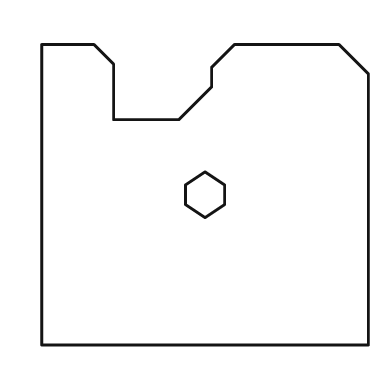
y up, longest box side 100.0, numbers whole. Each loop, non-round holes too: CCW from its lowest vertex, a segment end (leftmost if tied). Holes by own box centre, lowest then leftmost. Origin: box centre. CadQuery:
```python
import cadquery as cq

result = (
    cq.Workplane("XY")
    .moveTo(-50.0, -46.0)
    .lineTo(50.0, -46.0)
    .lineTo(50.0, 37.0)
    .lineTo(41.0, 46.0)
    .lineTo(9.0, 46.0)
    .lineTo(2.0, 39.0)
    .lineTo(2.0, 33.0)
    .lineTo(-8.0, 23.0)
    .lineTo(-28.0, 23.0)
    .lineTo(-28.0, 40.0)
    .lineTo(-34.0, 46.0)
    .lineTo(-50.0, 46.0)
    .close()
    .moveTo(0.0, -7.0)
    .lineTo(6.0, -3.0)
    .lineTo(6.0, 3.0)
    .lineTo(0.0, 7.0)
    .lineTo(-6.0, 3.0)
    .lineTo(-6.0, -3.0)
    .close()
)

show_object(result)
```